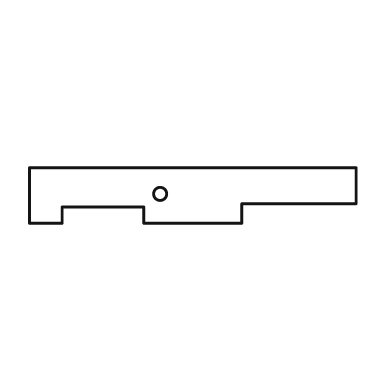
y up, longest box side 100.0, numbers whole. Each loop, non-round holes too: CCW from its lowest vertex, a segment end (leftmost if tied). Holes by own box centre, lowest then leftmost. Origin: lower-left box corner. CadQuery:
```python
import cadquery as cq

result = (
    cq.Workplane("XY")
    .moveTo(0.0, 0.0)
    .lineTo(10.0, 0.0)
    .lineTo(10.0, 5.0)
    .lineTo(35.0, 5.0)
    .lineTo(35.0, 0.0)
    .lineTo(65.0, 0.0)
    .lineTo(65.0, 6.0)
    .lineTo(100.0, 6.0)
    .lineTo(100.0, 17.0)
    .lineTo(0.0, 17.0)
    .close()
    .moveTo(40.0, 9.0)
    .circle(2.0)
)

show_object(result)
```